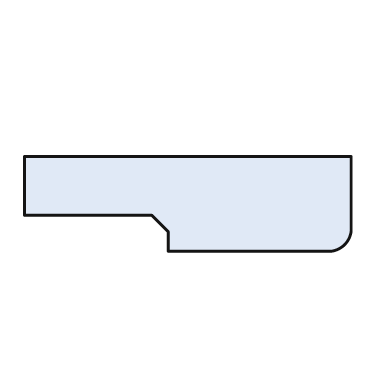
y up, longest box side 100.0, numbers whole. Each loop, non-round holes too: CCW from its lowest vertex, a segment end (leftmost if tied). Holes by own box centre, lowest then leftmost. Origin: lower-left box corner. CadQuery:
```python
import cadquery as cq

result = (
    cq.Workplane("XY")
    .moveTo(44.0, 0.0)
    .lineTo(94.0, 0.0)
    .threePointArc((98.0, 2.0), (100.0, 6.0))
    .lineTo(100.0, 29.0)
    .lineTo(0.0, 29.0)
    .lineTo(0.0, 11.0)
    .lineTo(39.0, 11.0)
    .lineTo(44.0, 6.0)
    .close()
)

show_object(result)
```